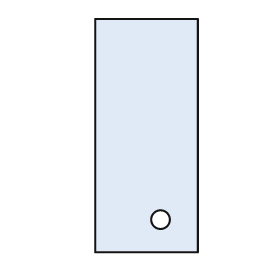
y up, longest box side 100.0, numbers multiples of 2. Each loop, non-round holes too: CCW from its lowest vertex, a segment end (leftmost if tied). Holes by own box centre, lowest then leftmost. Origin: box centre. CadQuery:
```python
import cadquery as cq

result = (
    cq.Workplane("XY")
    .moveTo(-22.0, -50.0)
    .lineTo(22.0, -50.0)
    .lineTo(22.0, 50.0)
    .lineTo(-22.0, 50.0)
    .close()
    .moveTo(6.0, -36.0)
    .circle(4.0)
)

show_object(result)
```